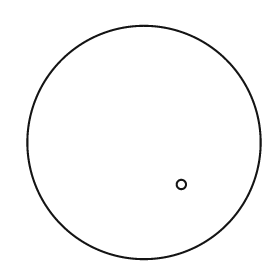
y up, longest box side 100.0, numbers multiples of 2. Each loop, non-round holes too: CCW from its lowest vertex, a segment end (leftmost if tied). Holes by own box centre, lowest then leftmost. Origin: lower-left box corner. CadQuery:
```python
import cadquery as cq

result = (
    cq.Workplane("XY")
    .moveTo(50.0, 50.0)
    .circle(50.0)
    .moveTo(66.0, 32.0)
    .circle(2.0)
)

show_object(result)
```